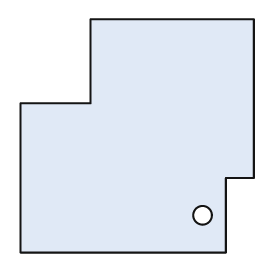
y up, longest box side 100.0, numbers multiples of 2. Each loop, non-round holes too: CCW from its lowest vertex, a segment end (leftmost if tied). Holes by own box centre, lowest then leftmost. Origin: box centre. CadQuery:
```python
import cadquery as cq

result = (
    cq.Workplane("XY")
    .moveTo(-50.0, -50.0)
    .lineTo(38.0, -50.0)
    .lineTo(38.0, -18.0)
    .lineTo(50.0, -18.0)
    .lineTo(50.0, 50.0)
    .lineTo(-20.0, 50.0)
    .lineTo(-20.0, 14.0)
    .lineTo(-50.0, 14.0)
    .close()
    .moveTo(28.0, -34.0)
    .circle(4.0)
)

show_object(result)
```